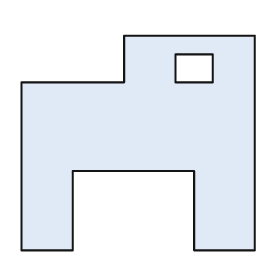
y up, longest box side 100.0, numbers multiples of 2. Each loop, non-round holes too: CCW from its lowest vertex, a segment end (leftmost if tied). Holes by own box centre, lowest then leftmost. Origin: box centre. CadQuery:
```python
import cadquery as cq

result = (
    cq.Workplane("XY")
    .moveTo(-50.0, -46.0)
    .lineTo(-28.0, -46.0)
    .lineTo(-28.0, -12.0)
    .lineTo(24.0, -12.0)
    .lineTo(24.0, -46.0)
    .lineTo(50.0, -46.0)
    .lineTo(50.0, 46.0)
    .lineTo(-6.0, 46.0)
    .lineTo(-6.0, 26.0)
    .lineTo(-50.0, 26.0)
    .close()
    .moveTo(16.0, 26.0)
    .lineTo(32.0, 26.0)
    .lineTo(32.0, 38.0)
    .lineTo(16.0, 38.0)
    .close()
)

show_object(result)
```